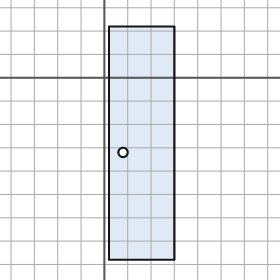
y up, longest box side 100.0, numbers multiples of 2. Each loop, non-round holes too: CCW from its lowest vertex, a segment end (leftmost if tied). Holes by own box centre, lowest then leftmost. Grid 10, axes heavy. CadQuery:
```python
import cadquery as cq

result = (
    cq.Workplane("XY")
    .moveTo(2.0, -78.0)
    .lineTo(30.0, -78.0)
    .lineTo(30.0, 22.0)
    .lineTo(2.0, 22.0)
    .close()
    .moveTo(8.0, -32.0)
    .circle(2.0)
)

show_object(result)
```